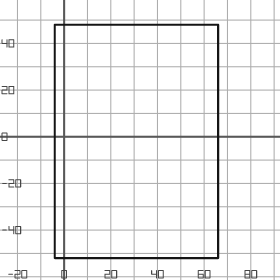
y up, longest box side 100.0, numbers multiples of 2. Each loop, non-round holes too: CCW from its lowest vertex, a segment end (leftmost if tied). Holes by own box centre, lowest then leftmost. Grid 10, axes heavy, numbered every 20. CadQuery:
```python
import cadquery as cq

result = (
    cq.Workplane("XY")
    .moveTo(-4.0, -52.0)
    .lineTo(66.0, -52.0)
    .lineTo(66.0, 48.0)
    .lineTo(-4.0, 48.0)
    .close()
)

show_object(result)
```